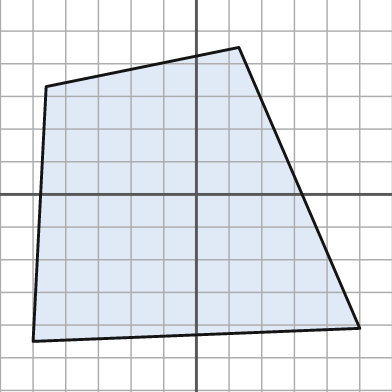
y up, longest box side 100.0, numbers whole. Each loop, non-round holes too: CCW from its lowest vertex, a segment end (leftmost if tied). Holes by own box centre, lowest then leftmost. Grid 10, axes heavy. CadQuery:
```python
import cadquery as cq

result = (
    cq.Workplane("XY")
    .moveTo(-50.0, -45.0)
    .lineTo(50.0, -41.0)
    .lineTo(13.0, 45.0)
    .lineTo(-46.0, 33.0)
    .close()
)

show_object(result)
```